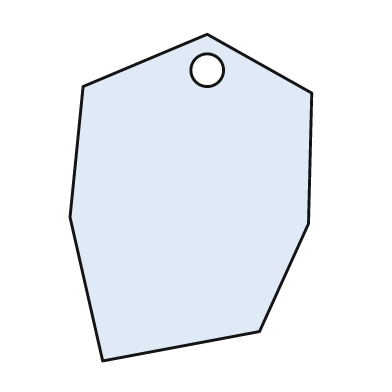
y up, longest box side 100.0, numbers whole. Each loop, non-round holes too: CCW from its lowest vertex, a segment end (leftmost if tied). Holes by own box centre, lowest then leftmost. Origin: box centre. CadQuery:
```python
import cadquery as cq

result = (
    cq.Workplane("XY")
    .moveTo(-27.0, -50.0)
    .lineTo(21.0, -41.0)
    .lineTo(36.0, -8.0)
    .lineTo(37.0, 32.0)
    .lineTo(5.0, 50.0)
    .lineTo(-33.0, 34.0)
    .lineTo(-37.0, -6.0)
    .close()
    .moveTo(5.0, 39.0)
    .circle(5.0)
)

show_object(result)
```